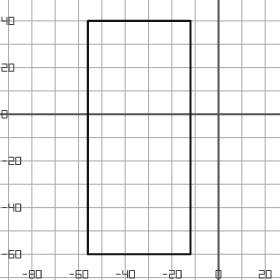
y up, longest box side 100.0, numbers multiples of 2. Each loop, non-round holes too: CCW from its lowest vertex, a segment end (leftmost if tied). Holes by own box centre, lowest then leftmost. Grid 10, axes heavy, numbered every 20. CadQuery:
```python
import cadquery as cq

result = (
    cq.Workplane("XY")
    .moveTo(-56.0, -60.0)
    .lineTo(-12.0, -60.0)
    .lineTo(-12.0, 40.0)
    .lineTo(-56.0, 40.0)
    .close()
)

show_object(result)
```